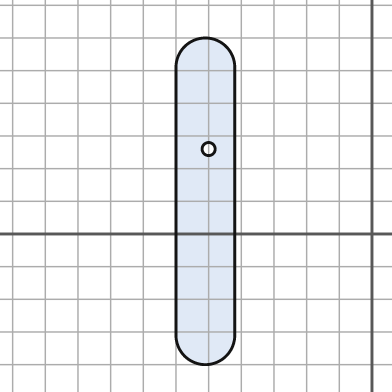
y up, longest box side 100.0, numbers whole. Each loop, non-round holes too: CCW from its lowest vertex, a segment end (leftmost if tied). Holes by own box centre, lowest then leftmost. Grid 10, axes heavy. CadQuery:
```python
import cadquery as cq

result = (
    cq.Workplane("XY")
    .moveTo(-60.0, -31.0)
    .threePointArc((-51.0, -40.0), (-42.0, -31.0))
    .lineTo(-42.0, 51.0)
    .threePointArc((-51.0, 60.0), (-60.0, 51.0))
    .close()
    .moveTo(-50.0, 26.0)
    .circle(2.0)
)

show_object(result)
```